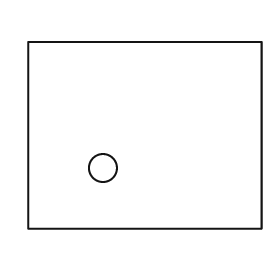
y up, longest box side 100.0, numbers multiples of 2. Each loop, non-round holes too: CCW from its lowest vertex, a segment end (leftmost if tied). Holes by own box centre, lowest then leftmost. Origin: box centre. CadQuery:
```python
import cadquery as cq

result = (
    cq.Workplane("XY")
    .moveTo(-50.0, -40.0)
    .lineTo(50.0, -40.0)
    .lineTo(50.0, 40.0)
    .lineTo(-50.0, 40.0)
    .close()
    .moveTo(-18.0, -14.0)
    .circle(6.0)
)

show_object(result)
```